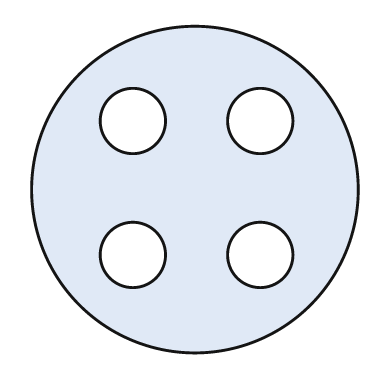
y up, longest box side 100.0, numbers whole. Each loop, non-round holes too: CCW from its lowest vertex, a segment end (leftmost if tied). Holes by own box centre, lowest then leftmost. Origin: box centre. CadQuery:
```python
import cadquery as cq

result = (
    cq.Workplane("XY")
    .moveTo(0.0, 0.0)
    .circle(50.0)
    .moveTo(-19.0, -20.0)
    .circle(10.0)
    .moveTo(20.0, -20.0)
    .circle(10.0)
    .moveTo(-19.0, 21.0)
    .circle(10.0)
    .moveTo(20.0, 21.0)
    .circle(10.0)
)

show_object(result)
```